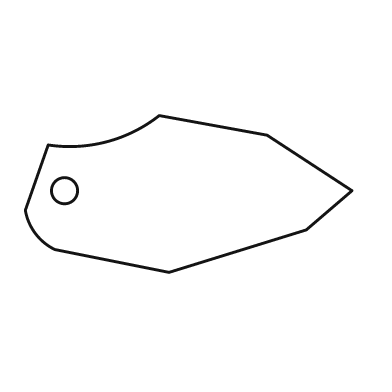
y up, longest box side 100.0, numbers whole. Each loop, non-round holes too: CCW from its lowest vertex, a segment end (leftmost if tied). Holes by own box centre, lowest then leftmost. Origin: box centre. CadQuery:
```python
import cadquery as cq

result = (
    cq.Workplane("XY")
    .moveTo(-6.0, -24.0)
    .lineTo(36.0, -11.0)
    .lineTo(50.0, 1.0)
    .lineTo(24.0, 18.0)
    .lineTo(-9.0, 24.0)
    .threePointArc((-25.0, 16.0), (-43.0, 15.0))
    .lineTo(-50.0, -5.0)
    .threePointArc((-47.0, -12.0), (-41.0, -17.0))
    .close()
    .moveTo(-38.0, 1.0)
    .circle(4.0)
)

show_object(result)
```